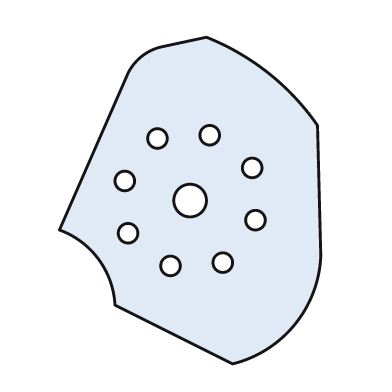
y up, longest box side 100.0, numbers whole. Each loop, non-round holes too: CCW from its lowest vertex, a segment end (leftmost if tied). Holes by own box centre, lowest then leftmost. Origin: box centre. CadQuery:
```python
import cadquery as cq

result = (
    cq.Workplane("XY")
    .moveTo(13.0, -50.0)
    .threePointArc((32.0, -38.0), (40.0, -17.0))
    .lineTo(39.0, 23.0)
    .threePointArc((24.0, 39.0), (5.0, 50.0))
    .lineTo(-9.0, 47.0)
    .threePointArc((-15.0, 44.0), (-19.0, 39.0))
    .lineTo(-40.0, -9.0)
    .threePointArc((-28.0, -18.0), (-23.0, -32.0))
    .close()
    .moveTo(-6.0, -20.0)
    .circle(3.0)
    .moveTo(10.0, -19.0)
    .circle(3.0)
    .moveTo(-19.0, -10.0)
    .circle(3.0)
    .moveTo(20.0, -6.0)
    .circle(3.0)
    .moveTo(0.0, 0.0)
    .circle(5.0)
    .moveTo(-20.0, 6.0)
    .circle(3.0)
    .moveTo(19.0, 10.0)
    .circle(3.0)
    .moveTo(-10.0, 19.0)
    .circle(3.0)
    .moveTo(6.0, 20.0)
    .circle(3.0)
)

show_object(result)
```